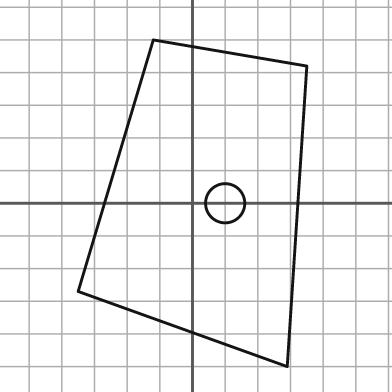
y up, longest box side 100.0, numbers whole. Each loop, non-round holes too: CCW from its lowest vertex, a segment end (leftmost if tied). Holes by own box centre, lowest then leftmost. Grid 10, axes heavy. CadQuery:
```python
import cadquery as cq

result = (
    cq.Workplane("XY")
    .moveTo(29.0, -50.0)
    .lineTo(35.0, 42.0)
    .lineTo(-12.0, 50.0)
    .lineTo(-35.0, -27.0)
    .close()
    .moveTo(10.0, 0.0)
    .circle(6.0)
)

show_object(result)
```